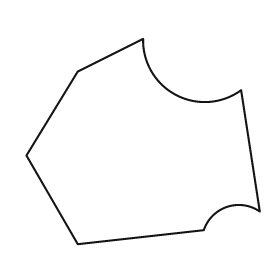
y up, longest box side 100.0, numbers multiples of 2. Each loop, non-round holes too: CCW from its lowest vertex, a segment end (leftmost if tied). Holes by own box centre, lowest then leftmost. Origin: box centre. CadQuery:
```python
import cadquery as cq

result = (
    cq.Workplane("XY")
    .moveTo(-28.0, -44.0)
    .lineTo(26.0, -38.0)
    .threePointArc((36.0, -28.0), (50.0, -30.0))
    .lineTo(42.0, 22.0)
    .threePointArc((14.0, 20.0), (0.0, 44.0))
    .lineTo(-28.0, 30.0)
    .lineTo(-50.0, -6.0)
    .close()
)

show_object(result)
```